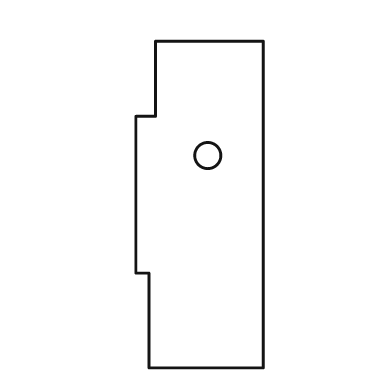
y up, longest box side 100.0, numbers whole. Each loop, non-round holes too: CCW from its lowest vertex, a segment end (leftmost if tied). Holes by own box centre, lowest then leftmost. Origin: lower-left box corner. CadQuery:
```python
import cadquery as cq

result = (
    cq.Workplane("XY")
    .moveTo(4.0, 0.0)
    .lineTo(39.0, 0.0)
    .lineTo(39.0, 100.0)
    .lineTo(6.0, 100.0)
    .lineTo(6.0, 77.0)
    .lineTo(0.0, 77.0)
    .lineTo(0.0, 29.0)
    .lineTo(4.0, 29.0)
    .close()
    .moveTo(22.0, 65.0)
    .circle(4.0)
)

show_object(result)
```